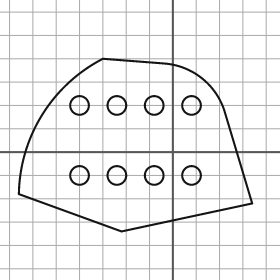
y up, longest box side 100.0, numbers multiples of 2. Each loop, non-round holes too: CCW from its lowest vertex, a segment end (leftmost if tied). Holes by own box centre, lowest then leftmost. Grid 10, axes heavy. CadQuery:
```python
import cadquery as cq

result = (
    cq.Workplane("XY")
    .moveTo(-22.0, -34.0)
    .lineTo(34.0, -22.0)
    .lineTo(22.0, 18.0)
    .threePointArc((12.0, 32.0), (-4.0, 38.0))
    .lineTo(-30.0, 40.0)
    .threePointArc((-56.0, 16.0), (-66.0, -18.0))
    .close()
    .moveTo(-40.0, -10.0)
    .circle(4.0)
    .moveTo(-24.0, -10.0)
    .circle(4.0)
    .moveTo(-8.0, -10.0)
    .circle(4.0)
    .moveTo(8.0, -10.0)
    .circle(4.0)
    .moveTo(-40.0, 20.0)
    .circle(4.0)
    .moveTo(-24.0, 20.0)
    .circle(4.0)
    .moveTo(-8.0, 20.0)
    .circle(4.0)
    .moveTo(8.0, 20.0)
    .circle(4.0)
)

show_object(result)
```